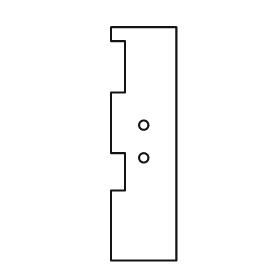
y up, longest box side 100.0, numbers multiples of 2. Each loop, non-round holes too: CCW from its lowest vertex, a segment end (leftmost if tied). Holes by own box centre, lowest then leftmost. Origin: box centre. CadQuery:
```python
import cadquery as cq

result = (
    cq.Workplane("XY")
    .moveTo(-14.0, -50.0)
    .lineTo(14.0, -50.0)
    .lineTo(14.0, 50.0)
    .lineTo(-14.0, 50.0)
    .lineTo(-14.0, 44.0)
    .lineTo(-8.0, 44.0)
    .lineTo(-8.0, 22.0)
    .lineTo(-14.0, 22.0)
    .lineTo(-14.0, -4.0)
    .lineTo(-8.0, -4.0)
    .lineTo(-8.0, -20.0)
    .lineTo(-14.0, -20.0)
    .close()
    .moveTo(0.0, -6.0)
    .circle(2.0)
    .moveTo(0.0, 8.0)
    .circle(2.0)
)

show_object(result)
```